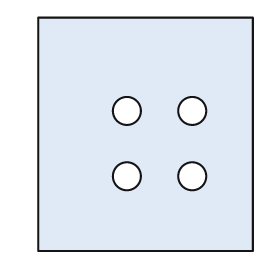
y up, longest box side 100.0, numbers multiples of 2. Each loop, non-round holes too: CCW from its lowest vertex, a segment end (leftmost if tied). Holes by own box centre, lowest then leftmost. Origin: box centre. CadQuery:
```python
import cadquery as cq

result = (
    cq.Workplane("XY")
    .moveTo(-46.0, -50.0)
    .lineTo(46.0, -50.0)
    .lineTo(46.0, 50.0)
    .lineTo(-46.0, 50.0)
    .close()
    .moveTo(-8.0, -18.0)
    .circle(6.0)
    .moveTo(20.0, -18.0)
    .circle(6.0)
    .moveTo(-8.0, 10.0)
    .circle(6.0)
    .moveTo(20.0, 10.0)
    .circle(6.0)
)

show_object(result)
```